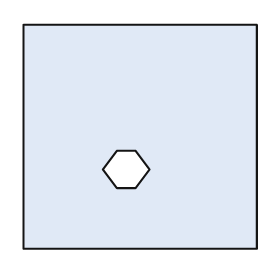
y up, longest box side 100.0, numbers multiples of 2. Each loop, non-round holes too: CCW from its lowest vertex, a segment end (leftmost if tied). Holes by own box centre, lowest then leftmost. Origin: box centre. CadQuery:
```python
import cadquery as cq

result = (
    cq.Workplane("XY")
    .moveTo(-50.0, -48.0)
    .lineTo(50.0, -48.0)
    .lineTo(50.0, 48.0)
    .lineTo(-50.0, 48.0)
    .close()
    .moveTo(-10.0, -22.0)
    .lineTo(-2.0, -22.0)
    .lineTo(4.0, -14.0)
    .lineTo(-2.0, -6.0)
    .lineTo(-10.0, -6.0)
    .lineTo(-16.0, -14.0)
    .close()
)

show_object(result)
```